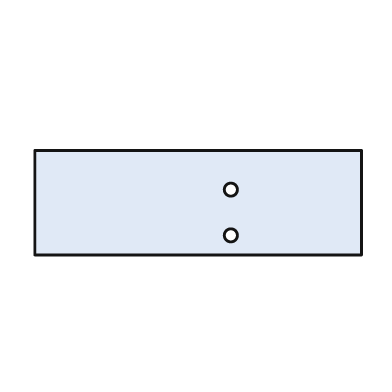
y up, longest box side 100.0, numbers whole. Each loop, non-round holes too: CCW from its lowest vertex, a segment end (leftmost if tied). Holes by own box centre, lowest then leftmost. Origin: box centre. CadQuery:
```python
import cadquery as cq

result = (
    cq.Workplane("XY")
    .moveTo(-50.0, -16.0)
    .lineTo(50.0, -16.0)
    .lineTo(50.0, 16.0)
    .lineTo(-50.0, 16.0)
    .close()
    .moveTo(10.0, -10.0)
    .circle(2.0)
    .moveTo(10.0, 4.0)
    .circle(2.0)
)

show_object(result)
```